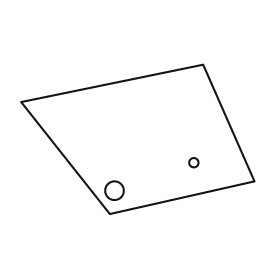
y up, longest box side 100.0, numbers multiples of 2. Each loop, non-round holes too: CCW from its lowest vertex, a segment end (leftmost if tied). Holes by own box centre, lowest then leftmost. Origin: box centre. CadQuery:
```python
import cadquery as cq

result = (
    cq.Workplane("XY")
    .moveTo(-12.0, -32.0)
    .lineTo(50.0, -18.0)
    .lineTo(28.0, 32.0)
    .lineTo(-50.0, 16.0)
    .close()
    .moveTo(-10.0, -22.0)
    .circle(4.0)
    .moveTo(24.0, -10.0)
    .circle(2.0)
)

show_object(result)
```